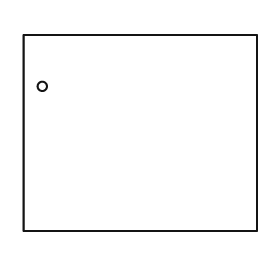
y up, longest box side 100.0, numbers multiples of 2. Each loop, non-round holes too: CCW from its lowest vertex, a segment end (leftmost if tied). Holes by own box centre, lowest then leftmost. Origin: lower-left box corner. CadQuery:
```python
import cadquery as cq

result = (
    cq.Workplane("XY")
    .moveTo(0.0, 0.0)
    .lineTo(100.0, 0.0)
    .lineTo(100.0, 84.0)
    .lineTo(0.0, 84.0)
    .close()
    .moveTo(8.0, 62.0)
    .circle(2.0)
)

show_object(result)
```